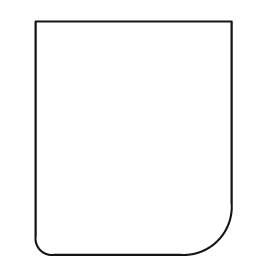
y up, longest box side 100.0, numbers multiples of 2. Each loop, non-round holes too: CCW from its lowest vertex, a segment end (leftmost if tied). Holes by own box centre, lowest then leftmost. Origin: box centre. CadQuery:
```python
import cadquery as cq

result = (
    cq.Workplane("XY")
    .moveTo(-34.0, -50.0)
    .lineTo(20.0, -50.0)
    .threePointArc((36.0, -44.0), (42.0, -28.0))
    .lineTo(42.0, 50.0)
    .lineTo(-42.0, 50.0)
    .lineTo(-42.0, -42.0)
    .threePointArc((-40.0, -48.0), (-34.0, -50.0))
    .close()
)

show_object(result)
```